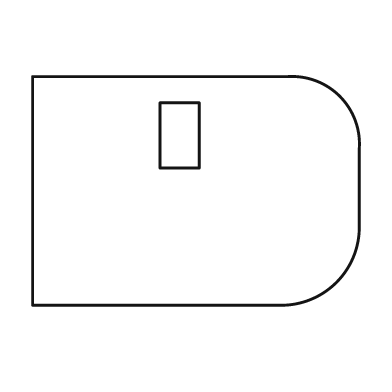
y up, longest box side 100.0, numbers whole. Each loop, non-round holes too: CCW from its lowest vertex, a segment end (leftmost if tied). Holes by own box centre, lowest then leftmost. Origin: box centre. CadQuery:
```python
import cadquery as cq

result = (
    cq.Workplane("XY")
    .moveTo(-50.0, -35.0)
    .lineTo(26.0, -35.0)
    .threePointArc((43.0, -28.0), (50.0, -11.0))
    .lineTo(50.0, 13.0)
    .threePointArc((44.0, 29.0), (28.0, 35.0))
    .lineTo(-50.0, 35.0)
    .close()
    .moveTo(-11.0, 7.0)
    .lineTo(1.0, 7.0)
    .lineTo(1.0, 27.0)
    .lineTo(-11.0, 27.0)
    .close()
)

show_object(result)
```